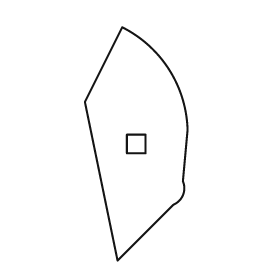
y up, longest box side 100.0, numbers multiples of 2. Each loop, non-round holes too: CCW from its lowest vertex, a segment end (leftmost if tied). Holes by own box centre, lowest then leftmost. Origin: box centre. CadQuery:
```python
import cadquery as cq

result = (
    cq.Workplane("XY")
    .moveTo(-8.0, -50.0)
    .lineTo(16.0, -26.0)
    .threePointArc((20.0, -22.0), (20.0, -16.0))
    .lineTo(22.0, 6.0)
    .threePointArc((14.0, 32.0), (-6.0, 50.0))
    .lineTo(-22.0, 18.0)
    .close()
    .moveTo(-4.0, -4.0)
    .lineTo(4.0, -4.0)
    .lineTo(4.0, 4.0)
    .lineTo(-4.0, 4.0)
    .close()
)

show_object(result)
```